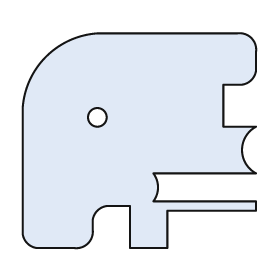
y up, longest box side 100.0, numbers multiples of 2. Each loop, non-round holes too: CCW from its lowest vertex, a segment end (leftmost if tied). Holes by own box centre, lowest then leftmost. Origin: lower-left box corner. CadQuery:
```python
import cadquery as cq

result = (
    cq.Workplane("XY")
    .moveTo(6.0, 0.0)
    .lineTo(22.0, 0.0)
    .threePointArc((28.0, 2.0), (30.0, 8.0))
    .lineTo(30.0, 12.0)
    .threePointArc((32.0, 16.0), (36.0, 18.0))
    .lineTo(46.0, 18.0)
    .lineTo(46.0, 0.0)
    .lineTo(62.0, 0.0)
    .lineTo(62.0, 16.0)
    .lineTo(100.0, 16.0)
    .lineTo(100.0, 20.0)
    .lineTo(56.0, 20.0)
    .threePointArc((58.0, 26.0), (56.0, 32.0))
    .lineTo(100.0, 32.0)
    .threePointArc((94.0, 42.0), (100.0, 52.0))
    .lineTo(86.0, 52.0)
    .lineTo(86.0, 70.0)
    .lineTo(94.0, 70.0)
    .threePointArc((98.0, 72.0), (100.0, 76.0))
    .lineTo(100.0, 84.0)
    .threePointArc((98.0, 90.0), (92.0, 92.0))
    .lineTo(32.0, 92.0)
    .threePointArc((10.0, 82.0), (0.0, 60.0))
    .lineTo(0.0, 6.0)
    .threePointArc((2.0, 2.0), (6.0, 0.0))
    .close()
    .moveTo(32.0, 56.0)
    .circle(4.0)
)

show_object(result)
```